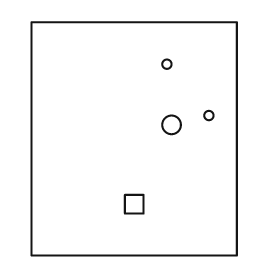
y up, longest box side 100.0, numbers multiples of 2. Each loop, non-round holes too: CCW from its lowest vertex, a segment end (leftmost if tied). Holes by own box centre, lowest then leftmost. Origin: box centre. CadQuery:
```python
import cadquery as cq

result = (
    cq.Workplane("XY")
    .moveTo(-44.0, -50.0)
    .lineTo(44.0, -50.0)
    .lineTo(44.0, 50.0)
    .lineTo(-44.0, 50.0)
    .close()
    .moveTo(-4.0, -32.0)
    .lineTo(4.0, -32.0)
    .lineTo(4.0, -24.0)
    .lineTo(-4.0, -24.0)
    .close()
    .moveTo(16.0, 6.0)
    .circle(4.0)
    .moveTo(32.0, 10.0)
    .circle(2.0)
    .moveTo(14.0, 32.0)
    .circle(2.0)
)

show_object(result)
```